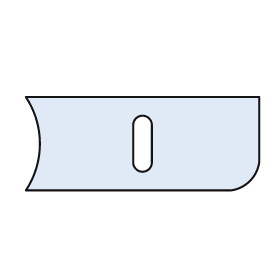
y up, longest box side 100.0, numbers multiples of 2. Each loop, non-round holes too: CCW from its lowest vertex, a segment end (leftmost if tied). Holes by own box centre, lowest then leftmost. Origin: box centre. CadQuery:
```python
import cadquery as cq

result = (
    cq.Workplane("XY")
    .moveTo(-50.0, -20.0)
    .lineTo(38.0, -20.0)
    .threePointArc((46.0, -16.0), (50.0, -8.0))
    .lineTo(50.0, 20.0)
    .lineTo(-50.0, 20.0)
    .threePointArc((-44.0, 0.0), (-50.0, -20.0))
    .close()
    .moveTo(-4.0, -8.0)
    .threePointArc((0.0, -12.0), (4.0, -8.0))
    .lineTo(4.0, 8.0)
    .threePointArc((0.0, 12.0), (-4.0, 8.0))
    .close()
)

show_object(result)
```